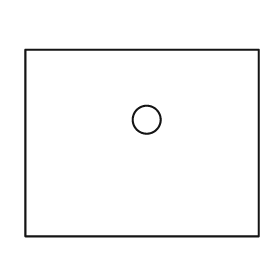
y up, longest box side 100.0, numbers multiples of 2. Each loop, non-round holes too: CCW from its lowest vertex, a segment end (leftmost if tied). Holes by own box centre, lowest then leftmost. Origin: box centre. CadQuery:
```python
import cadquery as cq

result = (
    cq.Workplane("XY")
    .moveTo(-50.0, -40.0)
    .lineTo(50.0, -40.0)
    .lineTo(50.0, 40.0)
    .lineTo(-50.0, 40.0)
    .close()
    .moveTo(2.0, 10.0)
    .circle(6.0)
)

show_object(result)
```